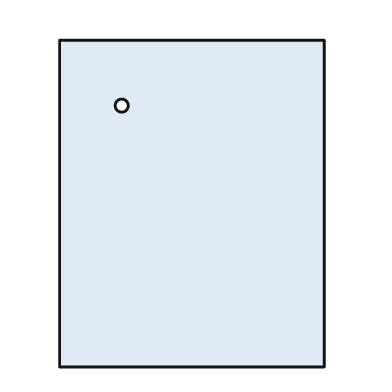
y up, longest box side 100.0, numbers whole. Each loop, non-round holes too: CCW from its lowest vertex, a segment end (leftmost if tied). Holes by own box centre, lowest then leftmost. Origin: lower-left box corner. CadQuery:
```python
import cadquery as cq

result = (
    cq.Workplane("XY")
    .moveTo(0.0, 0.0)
    .lineTo(81.0, 0.0)
    .lineTo(81.0, 100.0)
    .lineTo(0.0, 100.0)
    .close()
    .moveTo(19.0, 80.0)
    .circle(2.0)
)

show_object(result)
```